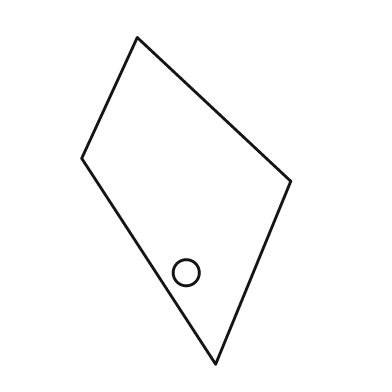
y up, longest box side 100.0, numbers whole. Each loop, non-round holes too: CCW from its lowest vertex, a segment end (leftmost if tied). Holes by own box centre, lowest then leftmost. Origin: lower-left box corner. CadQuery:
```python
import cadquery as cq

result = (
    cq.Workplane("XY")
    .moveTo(41.0, 0.0)
    .lineTo(64.0, 56.0)
    .lineTo(17.0, 100.0)
    .lineTo(0.0, 63.0)
    .close()
    .moveTo(32.0, 28.0)
    .circle(4.0)
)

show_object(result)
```